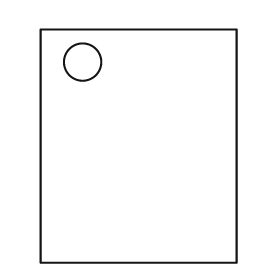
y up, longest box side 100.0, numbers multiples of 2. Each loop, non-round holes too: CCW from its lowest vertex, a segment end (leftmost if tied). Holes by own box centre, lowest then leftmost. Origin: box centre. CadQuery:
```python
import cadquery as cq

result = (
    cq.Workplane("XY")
    .moveTo(-42.0, -50.0)
    .lineTo(42.0, -50.0)
    .lineTo(42.0, 50.0)
    .lineTo(-42.0, 50.0)
    .close()
    .moveTo(-24.0, 36.0)
    .circle(8.0)
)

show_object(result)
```